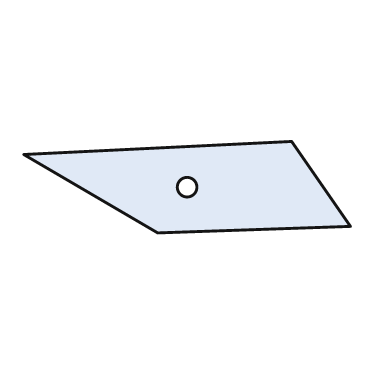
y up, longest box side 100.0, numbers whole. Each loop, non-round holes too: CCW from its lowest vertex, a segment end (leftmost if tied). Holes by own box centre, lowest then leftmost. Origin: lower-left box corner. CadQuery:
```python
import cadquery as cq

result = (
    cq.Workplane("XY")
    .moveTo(41.0, 0.0)
    .lineTo(100.0, 2.0)
    .lineTo(82.0, 28.0)
    .lineTo(0.0, 24.0)
    .close()
    .moveTo(50.0, 14.0)
    .circle(3.0)
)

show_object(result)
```